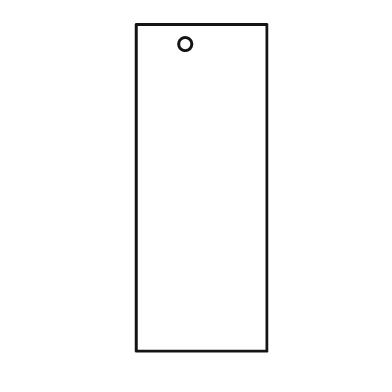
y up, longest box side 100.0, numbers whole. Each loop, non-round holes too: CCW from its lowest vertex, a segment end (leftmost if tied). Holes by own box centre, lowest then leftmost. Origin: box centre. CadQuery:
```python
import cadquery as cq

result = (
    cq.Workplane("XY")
    .moveTo(-20.0, -50.0)
    .lineTo(20.0, -50.0)
    .lineTo(20.0, 50.0)
    .lineTo(-20.0, 50.0)
    .close()
    .moveTo(-5.0, 44.0)
    .circle(2.0)
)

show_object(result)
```